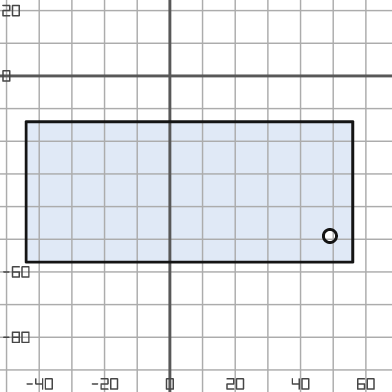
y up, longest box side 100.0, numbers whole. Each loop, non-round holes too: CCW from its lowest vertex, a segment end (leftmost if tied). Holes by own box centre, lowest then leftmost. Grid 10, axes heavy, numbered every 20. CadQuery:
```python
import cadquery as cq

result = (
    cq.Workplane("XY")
    .moveTo(-44.0, -57.0)
    .lineTo(56.0, -57.0)
    .lineTo(56.0, -14.0)
    .lineTo(-44.0, -14.0)
    .close()
    .moveTo(49.0, -49.0)
    .circle(2.0)
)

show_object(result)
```